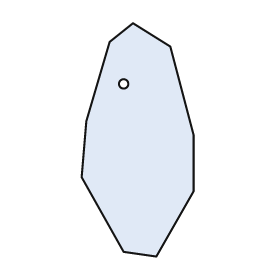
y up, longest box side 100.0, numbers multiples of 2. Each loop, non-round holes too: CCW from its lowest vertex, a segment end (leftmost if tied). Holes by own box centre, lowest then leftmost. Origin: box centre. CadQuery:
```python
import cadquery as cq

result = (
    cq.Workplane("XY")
    .moveTo(8.0, -50.0)
    .lineTo(24.0, -22.0)
    .lineTo(24.0, 2.0)
    .lineTo(14.0, 40.0)
    .lineTo(-2.0, 50.0)
    .lineTo(-12.0, 42.0)
    .lineTo(-22.0, 8.0)
    .lineTo(-24.0, -16.0)
    .lineTo(-6.0, -48.0)
    .close()
    .moveTo(-6.0, 24.0)
    .circle(2.0)
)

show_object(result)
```